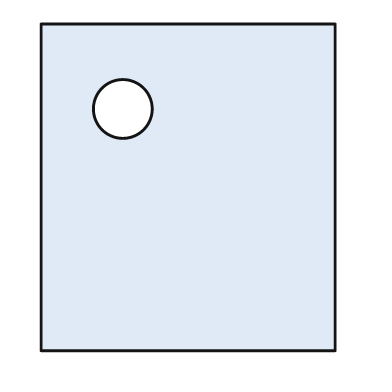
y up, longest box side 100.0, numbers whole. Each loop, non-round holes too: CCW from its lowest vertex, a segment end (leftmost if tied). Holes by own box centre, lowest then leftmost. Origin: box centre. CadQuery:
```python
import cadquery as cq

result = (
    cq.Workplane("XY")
    .moveTo(-45.0, -50.0)
    .lineTo(45.0, -50.0)
    .lineTo(45.0, 50.0)
    .lineTo(-45.0, 50.0)
    .close()
    .moveTo(-20.0, 24.0)
    .circle(9.0)
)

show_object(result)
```